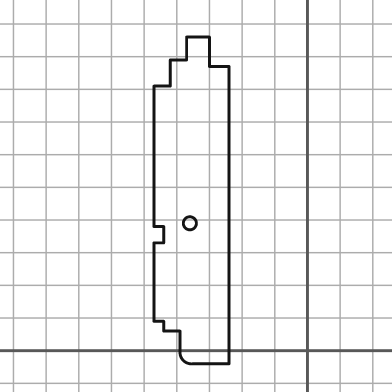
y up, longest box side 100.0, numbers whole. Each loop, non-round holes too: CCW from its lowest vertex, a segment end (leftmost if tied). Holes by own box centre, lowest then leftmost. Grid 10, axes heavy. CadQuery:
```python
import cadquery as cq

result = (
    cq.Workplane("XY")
    .moveTo(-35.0, -4.0)
    .lineTo(-24.0, -4.0)
    .lineTo(-24.0, 87.0)
    .lineTo(-30.0, 87.0)
    .lineTo(-30.0, 96.0)
    .lineTo(-37.0, 96.0)
    .lineTo(-37.0, 89.0)
    .lineTo(-42.0, 89.0)
    .lineTo(-42.0, 81.0)
    .lineTo(-47.0, 81.0)
    .lineTo(-47.0, 38.0)
    .lineTo(-44.0, 38.0)
    .lineTo(-44.0, 33.0)
    .lineTo(-47.0, 33.0)
    .lineTo(-47.0, 9.0)
    .lineTo(-44.0, 9.0)
    .lineTo(-44.0, 6.0)
    .lineTo(-39.0, 6.0)
    .lineTo(-39.0, 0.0)
    .threePointArc((-38.0, -3.0), (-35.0, -4.0))
    .close()
    .moveTo(-36.0, 39.0)
    .circle(2.0)
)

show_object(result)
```